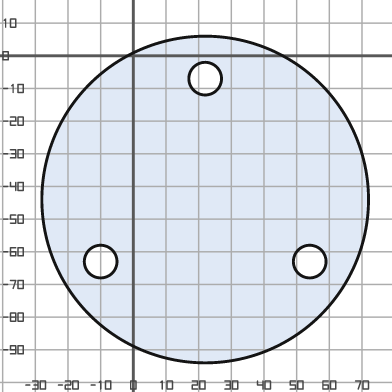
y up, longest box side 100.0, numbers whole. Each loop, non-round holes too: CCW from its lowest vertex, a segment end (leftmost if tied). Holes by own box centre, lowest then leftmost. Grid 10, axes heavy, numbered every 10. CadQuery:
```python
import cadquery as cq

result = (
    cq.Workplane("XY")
    .moveTo(22.0, -44.0)
    .circle(50.0)
    .moveTo(-10.0, -63.0)
    .circle(5.0)
    .moveTo(54.0, -63.0)
    .circle(5.0)
    .moveTo(22.0, -7.0)
    .circle(5.0)
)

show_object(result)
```